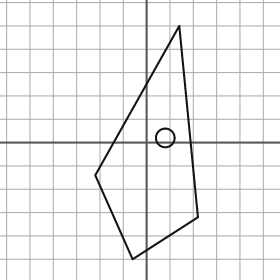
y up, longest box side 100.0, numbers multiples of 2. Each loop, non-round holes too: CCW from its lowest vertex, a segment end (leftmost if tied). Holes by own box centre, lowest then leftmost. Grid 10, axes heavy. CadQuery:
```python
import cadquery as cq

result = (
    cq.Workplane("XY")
    .moveTo(-6.0, -50.0)
    .lineTo(22.0, -32.0)
    .lineTo(14.0, 50.0)
    .lineTo(-22.0, -14.0)
    .close()
    .moveTo(8.0, 2.0)
    .circle(4.0)
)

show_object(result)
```